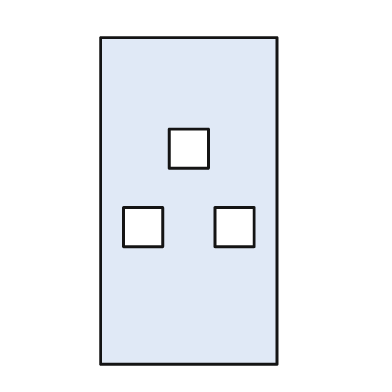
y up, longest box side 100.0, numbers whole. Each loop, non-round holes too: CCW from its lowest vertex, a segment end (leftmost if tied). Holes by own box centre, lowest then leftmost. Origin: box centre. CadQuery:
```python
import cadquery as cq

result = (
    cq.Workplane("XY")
    .moveTo(-27.0, -50.0)
    .lineTo(27.0, -50.0)
    .lineTo(27.0, 50.0)
    .lineTo(-27.0, 50.0)
    .close()
    .moveTo(-20.0, -14.0)
    .lineTo(-8.0, -14.0)
    .lineTo(-8.0, -2.0)
    .lineTo(-20.0, -2.0)
    .close()
    .moveTo(8.0, -14.0)
    .lineTo(20.0, -14.0)
    .lineTo(20.0, -2.0)
    .lineTo(8.0, -2.0)
    .close()
    .moveTo(-6.0, 10.0)
    .lineTo(6.0, 10.0)
    .lineTo(6.0, 22.0)
    .lineTo(-6.0, 22.0)
    .close()
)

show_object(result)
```